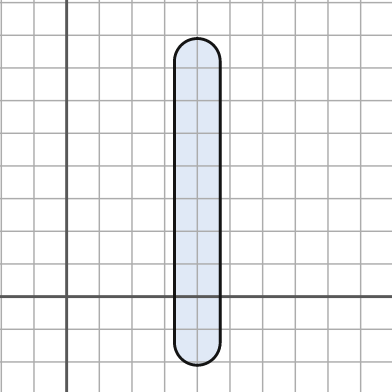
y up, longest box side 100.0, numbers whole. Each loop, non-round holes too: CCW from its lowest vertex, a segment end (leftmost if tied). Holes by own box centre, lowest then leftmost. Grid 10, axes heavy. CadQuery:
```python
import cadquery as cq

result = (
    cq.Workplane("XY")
    .moveTo(33.0, -14.0)
    .threePointArc((40.0, -21.0), (47.0, -14.0))
    .lineTo(47.0, 72.0)
    .threePointArc((40.0, 79.0), (33.0, 72.0))
    .close()
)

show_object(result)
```